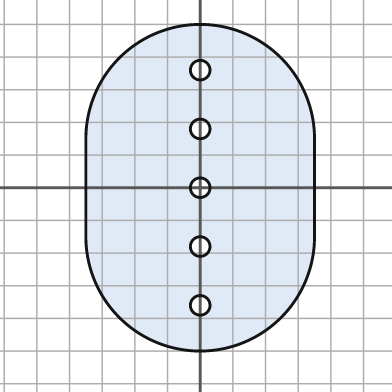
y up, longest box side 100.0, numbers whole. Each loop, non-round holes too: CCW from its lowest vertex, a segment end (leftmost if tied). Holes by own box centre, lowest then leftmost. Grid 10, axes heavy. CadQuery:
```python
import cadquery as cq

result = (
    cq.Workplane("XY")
    .moveTo(-35.0, -15.0)
    .threePointArc((0.0, -50.0), (35.0, -15.0))
    .lineTo(35.0, 15.0)
    .threePointArc((0.0, 50.0), (-35.0, 15.0))
    .close()
    .moveTo(0.0, -36.0)
    .circle(3.0)
    .moveTo(0.0, -18.0)
    .circle(3.0)
    .moveTo(0.0, 0.0)
    .circle(3.0)
    .moveTo(0.0, 18.0)
    .circle(3.0)
    .moveTo(0.0, 36.0)
    .circle(3.0)
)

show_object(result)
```